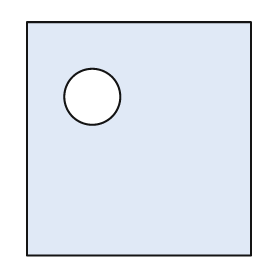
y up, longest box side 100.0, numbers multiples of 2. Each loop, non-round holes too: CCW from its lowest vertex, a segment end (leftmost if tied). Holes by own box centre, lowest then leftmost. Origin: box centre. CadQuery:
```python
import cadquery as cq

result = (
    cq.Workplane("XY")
    .moveTo(-48.0, -50.0)
    .lineTo(48.0, -50.0)
    .lineTo(48.0, 50.0)
    .lineTo(-48.0, 50.0)
    .close()
    .moveTo(-20.0, 18.0)
    .circle(12.0)
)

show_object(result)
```